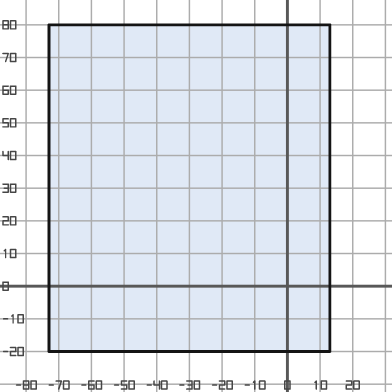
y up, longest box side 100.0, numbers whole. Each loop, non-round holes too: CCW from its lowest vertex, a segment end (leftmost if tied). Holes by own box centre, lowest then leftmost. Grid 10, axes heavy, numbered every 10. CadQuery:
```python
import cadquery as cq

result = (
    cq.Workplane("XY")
    .moveTo(-73.0, -20.0)
    .lineTo(13.0, -20.0)
    .lineTo(13.0, 80.0)
    .lineTo(-73.0, 80.0)
    .close()
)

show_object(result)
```